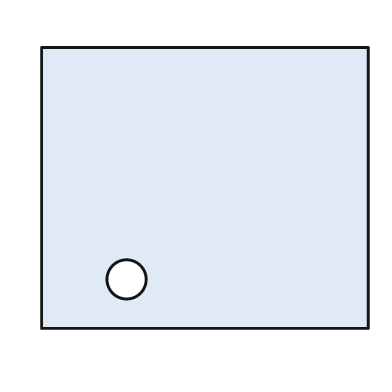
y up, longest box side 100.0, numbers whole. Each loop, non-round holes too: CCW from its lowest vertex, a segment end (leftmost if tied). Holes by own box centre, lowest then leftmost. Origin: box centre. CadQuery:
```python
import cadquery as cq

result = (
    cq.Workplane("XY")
    .moveTo(-50.0, -43.0)
    .lineTo(50.0, -43.0)
    .lineTo(50.0, 43.0)
    .lineTo(-50.0, 43.0)
    .close()
    .moveTo(-24.0, -28.0)
    .circle(6.0)
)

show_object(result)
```